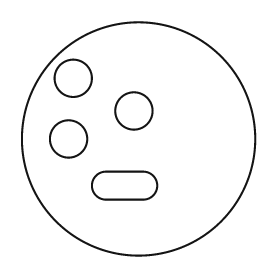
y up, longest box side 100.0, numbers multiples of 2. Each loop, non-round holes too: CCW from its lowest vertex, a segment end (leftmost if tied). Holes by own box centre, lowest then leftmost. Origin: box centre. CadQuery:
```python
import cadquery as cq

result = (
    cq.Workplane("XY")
    .moveTo(0.0, 0.0)
    .circle(50.0)
    .moveTo(-14.0, -26.0)
    .lineTo(2.0, -26.0)
    .threePointArc((8.0, -20.0), (2.0, -14.0))
    .lineTo(-14.0, -14.0)
    .threePointArc((-20.0, -20.0), (-14.0, -26.0))
    .close()
    .moveTo(-30.0, 0.0)
    .circle(8.0)
    .moveTo(-2.0, 12.0)
    .circle(8.0)
    .moveTo(-28.0, 26.0)
    .circle(8.0)
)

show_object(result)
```